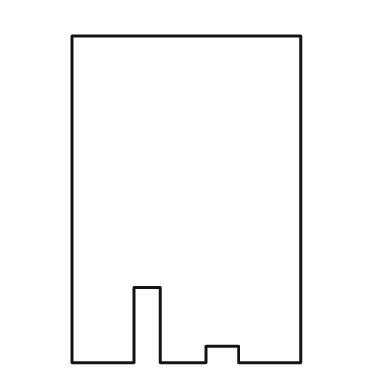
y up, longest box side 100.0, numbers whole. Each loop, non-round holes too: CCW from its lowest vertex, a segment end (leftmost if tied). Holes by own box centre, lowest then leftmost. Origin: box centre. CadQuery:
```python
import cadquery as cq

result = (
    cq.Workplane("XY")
    .moveTo(-35.0, -50.0)
    .lineTo(-16.0, -50.0)
    .lineTo(-16.0, -27.0)
    .lineTo(-8.0, -27.0)
    .lineTo(-8.0, -50.0)
    .lineTo(6.0, -50.0)
    .lineTo(6.0, -45.0)
    .lineTo(16.0, -45.0)
    .lineTo(16.0, -50.0)
    .lineTo(35.0, -50.0)
    .lineTo(35.0, 50.0)
    .lineTo(-35.0, 50.0)
    .close()
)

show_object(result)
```